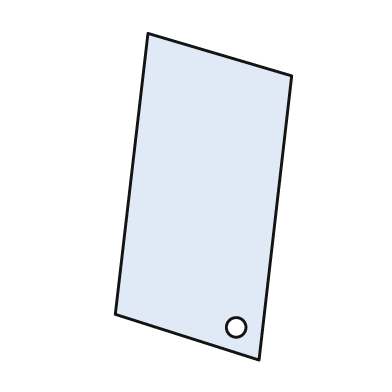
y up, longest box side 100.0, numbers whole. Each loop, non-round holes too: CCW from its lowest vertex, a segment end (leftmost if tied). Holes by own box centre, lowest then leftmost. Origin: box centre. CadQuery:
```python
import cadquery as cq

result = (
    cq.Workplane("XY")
    .moveTo(17.0, -50.0)
    .lineTo(27.0, 37.0)
    .lineTo(-17.0, 50.0)
    .lineTo(-27.0, -36.0)
    .close()
    .moveTo(10.0, -40.0)
    .circle(3.0)
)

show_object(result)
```